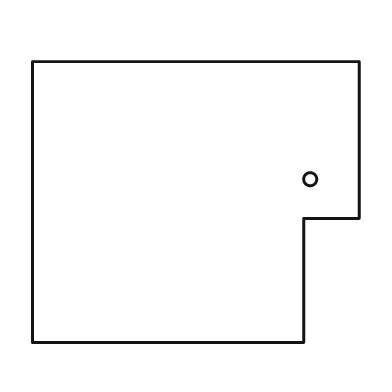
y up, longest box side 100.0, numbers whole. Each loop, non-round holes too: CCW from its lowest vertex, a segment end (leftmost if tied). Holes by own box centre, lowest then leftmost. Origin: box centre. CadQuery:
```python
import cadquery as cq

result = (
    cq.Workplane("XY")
    .moveTo(-50.0, -43.0)
    .lineTo(33.0, -43.0)
    .lineTo(33.0, -5.0)
    .lineTo(50.0, -5.0)
    .lineTo(50.0, 43.0)
    .lineTo(-50.0, 43.0)
    .close()
    .moveTo(35.0, 7.0)
    .circle(2.0)
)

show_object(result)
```